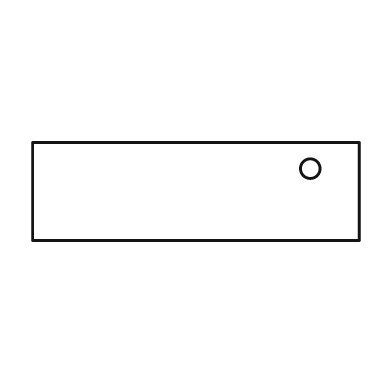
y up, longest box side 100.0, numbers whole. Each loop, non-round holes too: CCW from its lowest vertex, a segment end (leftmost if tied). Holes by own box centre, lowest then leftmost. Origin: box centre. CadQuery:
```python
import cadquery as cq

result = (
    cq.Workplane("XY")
    .moveTo(-50.0, -15.0)
    .lineTo(50.0, -15.0)
    .lineTo(50.0, 15.0)
    .lineTo(-50.0, 15.0)
    .close()
    .moveTo(35.0, 7.0)
    .circle(3.0)
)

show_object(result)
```